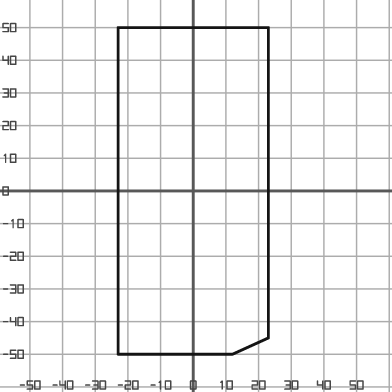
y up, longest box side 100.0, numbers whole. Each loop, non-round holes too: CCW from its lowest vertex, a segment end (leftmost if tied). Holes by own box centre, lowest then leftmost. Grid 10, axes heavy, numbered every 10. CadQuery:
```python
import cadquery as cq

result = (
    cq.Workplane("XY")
    .moveTo(-23.0, -50.0)
    .lineTo(12.0, -50.0)
    .lineTo(23.0, -45.0)
    .lineTo(23.0, 50.0)
    .lineTo(-23.0, 50.0)
    .close()
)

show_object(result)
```